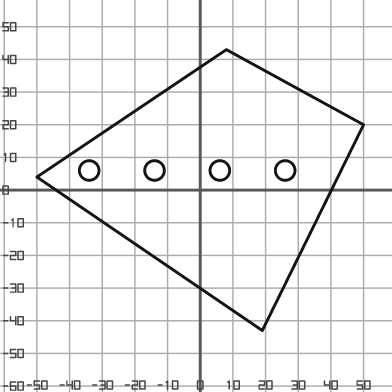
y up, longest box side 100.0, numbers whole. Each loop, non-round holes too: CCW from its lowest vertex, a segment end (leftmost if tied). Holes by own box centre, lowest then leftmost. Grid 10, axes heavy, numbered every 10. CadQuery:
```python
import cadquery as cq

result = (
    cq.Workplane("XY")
    .moveTo(19.0, -43.0)
    .lineTo(50.0, 20.0)
    .lineTo(8.0, 43.0)
    .lineTo(-50.0, 4.0)
    .close()
    .moveTo(-34.0, 6.0)
    .circle(3.0)
    .moveTo(-14.0, 6.0)
    .circle(3.0)
    .moveTo(6.0, 6.0)
    .circle(3.0)
    .moveTo(26.0, 6.0)
    .circle(3.0)
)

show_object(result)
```